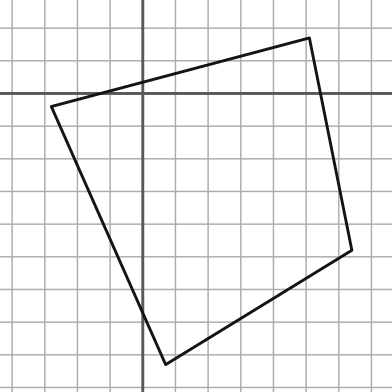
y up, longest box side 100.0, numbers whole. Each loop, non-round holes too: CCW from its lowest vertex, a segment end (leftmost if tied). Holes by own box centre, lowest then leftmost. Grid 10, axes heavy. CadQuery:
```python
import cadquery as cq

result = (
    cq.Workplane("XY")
    .moveTo(7.0, -83.0)
    .lineTo(64.0, -48.0)
    .lineTo(51.0, 17.0)
    .lineTo(-28.0, -4.0)
    .close()
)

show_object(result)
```